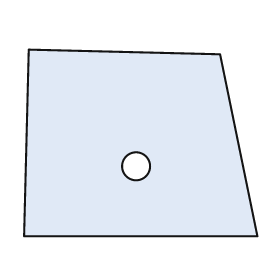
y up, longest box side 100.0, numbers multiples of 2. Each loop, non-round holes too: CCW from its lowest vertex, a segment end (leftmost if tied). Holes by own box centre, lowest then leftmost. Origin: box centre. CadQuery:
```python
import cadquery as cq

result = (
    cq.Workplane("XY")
    .moveTo(-50.0, -40.0)
    .lineTo(50.0, -40.0)
    .lineTo(34.0, 38.0)
    .lineTo(-48.0, 40.0)
    .close()
    .moveTo(-2.0, -10.0)
    .circle(6.0)
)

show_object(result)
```